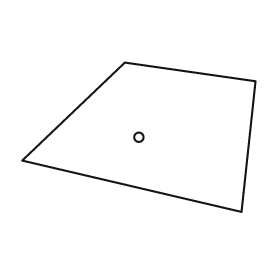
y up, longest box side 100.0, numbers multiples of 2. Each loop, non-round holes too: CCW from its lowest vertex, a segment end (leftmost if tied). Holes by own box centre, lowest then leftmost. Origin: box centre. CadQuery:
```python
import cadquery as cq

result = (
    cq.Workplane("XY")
    .moveTo(44.0, -32.0)
    .lineTo(50.0, 24.0)
    .lineTo(-6.0, 32.0)
    .lineTo(-50.0, -10.0)
    .close()
    .moveTo(0.0, 0.0)
    .circle(2.0)
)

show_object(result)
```